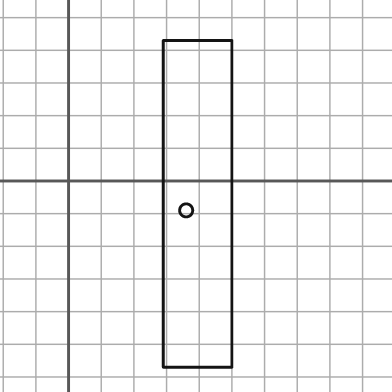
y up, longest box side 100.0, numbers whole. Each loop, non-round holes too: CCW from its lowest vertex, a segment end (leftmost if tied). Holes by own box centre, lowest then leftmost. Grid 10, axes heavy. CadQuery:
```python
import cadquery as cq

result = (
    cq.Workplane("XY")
    .moveTo(29.0, -57.0)
    .lineTo(50.0, -57.0)
    .lineTo(50.0, 43.0)
    .lineTo(29.0, 43.0)
    .close()
    .moveTo(36.0, -9.0)
    .circle(2.0)
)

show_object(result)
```